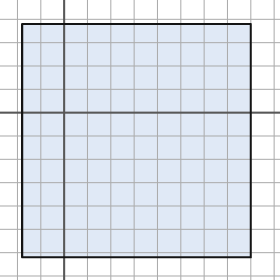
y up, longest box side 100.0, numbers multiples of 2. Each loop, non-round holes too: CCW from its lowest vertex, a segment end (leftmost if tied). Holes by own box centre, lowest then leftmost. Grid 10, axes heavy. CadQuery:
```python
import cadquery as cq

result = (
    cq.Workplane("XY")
    .moveTo(-18.0, -62.0)
    .lineTo(80.0, -62.0)
    .lineTo(80.0, 38.0)
    .lineTo(-18.0, 38.0)
    .close()
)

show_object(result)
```